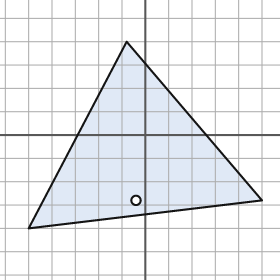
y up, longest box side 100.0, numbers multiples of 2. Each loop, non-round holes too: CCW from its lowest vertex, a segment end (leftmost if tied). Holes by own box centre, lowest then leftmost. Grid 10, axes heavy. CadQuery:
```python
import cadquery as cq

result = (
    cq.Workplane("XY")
    .moveTo(-50.0, -40.0)
    .lineTo(50.0, -28.0)
    .lineTo(-8.0, 40.0)
    .close()
    .moveTo(-4.0, -28.0)
    .circle(2.0)
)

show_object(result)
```